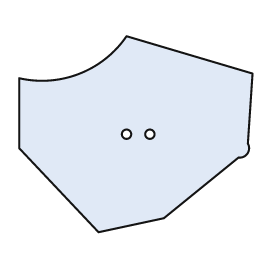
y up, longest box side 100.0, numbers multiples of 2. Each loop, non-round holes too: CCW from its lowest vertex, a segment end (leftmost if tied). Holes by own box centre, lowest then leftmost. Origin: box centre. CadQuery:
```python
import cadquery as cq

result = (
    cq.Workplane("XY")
    .moveTo(-16.0, -42.0)
    .lineTo(12.0, -36.0)
    .lineTo(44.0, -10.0)
    .threePointArc((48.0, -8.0), (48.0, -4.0))
    .lineTo(50.0, 26.0)
    .lineTo(-4.0, 42.0)
    .threePointArc((-24.0, 26.0), (-50.0, 24.0))
    .lineTo(-50.0, -6.0)
    .close()
    .moveTo(-4.0, 0.0)
    .circle(2.0)
    .moveTo(6.0, 0.0)
    .circle(2.0)
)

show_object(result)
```